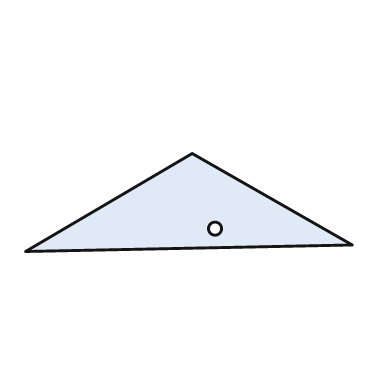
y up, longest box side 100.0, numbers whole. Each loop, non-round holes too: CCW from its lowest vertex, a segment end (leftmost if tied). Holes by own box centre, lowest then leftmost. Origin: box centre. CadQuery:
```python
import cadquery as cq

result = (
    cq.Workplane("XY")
    .moveTo(-50.0, -15.0)
    .lineTo(50.0, -13.0)
    .lineTo(1.0, 15.0)
    .close()
    .moveTo(8.0, -8.0)
    .circle(2.0)
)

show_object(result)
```